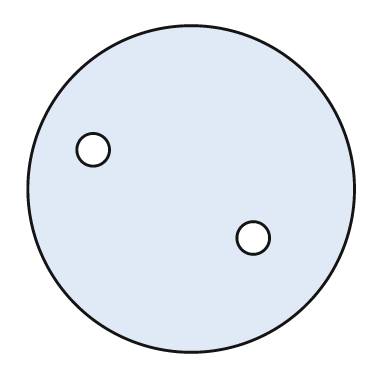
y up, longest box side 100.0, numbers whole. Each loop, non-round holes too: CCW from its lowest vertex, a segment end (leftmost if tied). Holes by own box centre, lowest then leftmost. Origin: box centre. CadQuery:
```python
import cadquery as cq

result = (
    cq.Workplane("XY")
    .moveTo(0.0, 0.0)
    .circle(50.0)
    .moveTo(19.0, -15.0)
    .circle(5.0)
    .moveTo(-30.0, 12.0)
    .circle(5.0)
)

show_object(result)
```